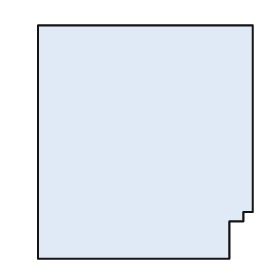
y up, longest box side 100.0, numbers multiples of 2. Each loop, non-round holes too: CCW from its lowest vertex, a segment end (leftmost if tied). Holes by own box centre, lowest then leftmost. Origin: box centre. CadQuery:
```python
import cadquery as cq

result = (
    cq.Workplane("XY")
    .moveTo(-46.0, -50.0)
    .lineTo(36.0, -50.0)
    .lineTo(36.0, -34.0)
    .lineTo(42.0, -34.0)
    .lineTo(42.0, -30.0)
    .lineTo(46.0, -30.0)
    .lineTo(46.0, 50.0)
    .lineTo(-46.0, 50.0)
    .close()
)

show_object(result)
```